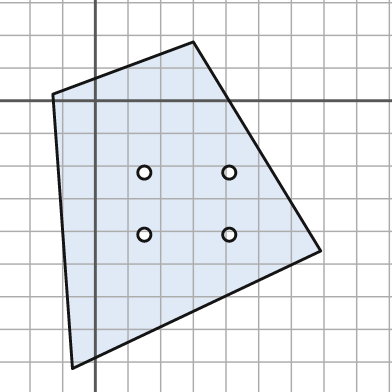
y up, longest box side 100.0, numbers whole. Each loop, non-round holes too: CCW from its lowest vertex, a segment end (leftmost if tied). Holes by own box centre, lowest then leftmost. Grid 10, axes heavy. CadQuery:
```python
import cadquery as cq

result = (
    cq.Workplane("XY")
    .moveTo(-7.0, -82.0)
    .lineTo(69.0, -46.0)
    .lineTo(30.0, 18.0)
    .lineTo(-13.0, 2.0)
    .close()
    .moveTo(15.0, -41.0)
    .circle(2.0)
    .moveTo(41.0, -41.0)
    .circle(2.0)
    .moveTo(15.0, -22.0)
    .circle(2.0)
    .moveTo(41.0, -22.0)
    .circle(2.0)
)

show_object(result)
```